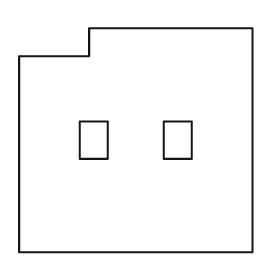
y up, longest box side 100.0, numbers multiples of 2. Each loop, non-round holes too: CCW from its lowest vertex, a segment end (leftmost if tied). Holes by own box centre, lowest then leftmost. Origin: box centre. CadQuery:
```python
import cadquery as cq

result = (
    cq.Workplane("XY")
    .moveTo(-50.0, -48.0)
    .lineTo(50.0, -48.0)
    .lineTo(50.0, 48.0)
    .lineTo(-20.0, 48.0)
    .lineTo(-20.0, 36.0)
    .lineTo(-50.0, 36.0)
    .close()
    .moveTo(-24.0, -8.0)
    .lineTo(-12.0, -8.0)
    .lineTo(-12.0, 8.0)
    .lineTo(-24.0, 8.0)
    .close()
    .moveTo(12.0, -8.0)
    .lineTo(24.0, -8.0)
    .lineTo(24.0, 8.0)
    .lineTo(12.0, 8.0)
    .close()
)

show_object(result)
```